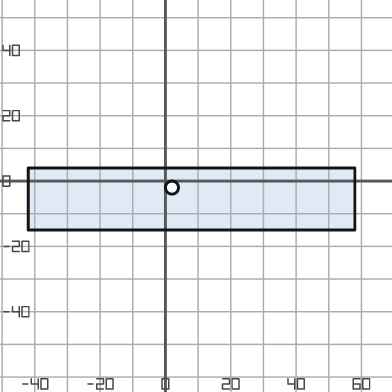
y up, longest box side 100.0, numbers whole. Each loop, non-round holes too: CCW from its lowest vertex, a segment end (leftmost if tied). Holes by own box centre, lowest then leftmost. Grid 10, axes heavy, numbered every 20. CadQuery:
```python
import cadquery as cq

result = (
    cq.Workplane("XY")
    .moveTo(-42.0, -15.0)
    .lineTo(58.0, -15.0)
    .lineTo(58.0, 4.0)
    .lineTo(-42.0, 4.0)
    .close()
    .moveTo(2.0, -2.0)
    .circle(2.0)
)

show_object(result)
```